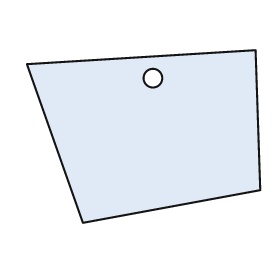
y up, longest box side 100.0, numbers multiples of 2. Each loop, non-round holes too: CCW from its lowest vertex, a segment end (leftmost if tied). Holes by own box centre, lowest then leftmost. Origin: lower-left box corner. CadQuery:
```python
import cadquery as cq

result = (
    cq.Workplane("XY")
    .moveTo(24.0, 0.0)
    .lineTo(100.0, 14.0)
    .lineTo(98.0, 74.0)
    .lineTo(0.0, 68.0)
    .close()
    .moveTo(54.0, 62.0)
    .circle(4.0)
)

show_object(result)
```